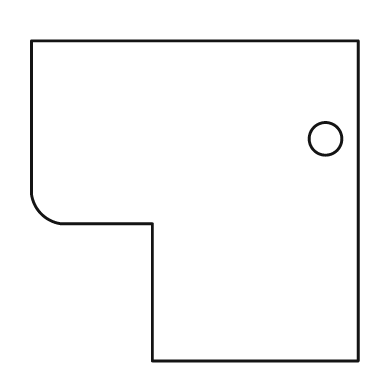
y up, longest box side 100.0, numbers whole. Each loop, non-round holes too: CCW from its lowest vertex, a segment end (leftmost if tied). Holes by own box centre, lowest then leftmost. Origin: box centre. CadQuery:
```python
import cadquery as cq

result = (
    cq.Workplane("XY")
    .moveTo(-13.0, -49.0)
    .lineTo(50.0, -49.0)
    .lineTo(50.0, 49.0)
    .lineTo(-50.0, 49.0)
    .lineTo(-50.0, 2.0)
    .threePointArc((-47.0, -4.0), (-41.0, -7.0))
    .lineTo(-13.0, -7.0)
    .close()
    .moveTo(40.0, 19.0)
    .circle(5.0)
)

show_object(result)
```